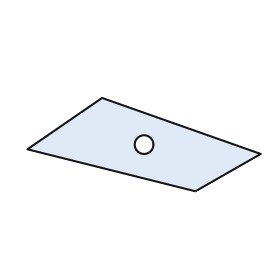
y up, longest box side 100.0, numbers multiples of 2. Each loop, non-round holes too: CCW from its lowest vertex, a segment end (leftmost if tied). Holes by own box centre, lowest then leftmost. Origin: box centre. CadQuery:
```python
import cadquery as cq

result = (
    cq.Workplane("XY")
    .moveTo(22.0, -20.0)
    .lineTo(50.0, -4.0)
    .lineTo(-18.0, 20.0)
    .lineTo(-50.0, -2.0)
    .close()
    .moveTo(0.0, 0.0)
    .circle(4.0)
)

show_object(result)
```